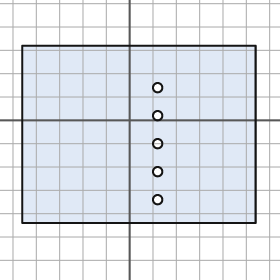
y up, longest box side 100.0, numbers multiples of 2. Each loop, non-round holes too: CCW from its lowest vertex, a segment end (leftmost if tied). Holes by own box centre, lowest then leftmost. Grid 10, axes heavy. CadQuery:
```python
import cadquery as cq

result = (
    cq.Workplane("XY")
    .moveTo(-46.0, -44.0)
    .lineTo(54.0, -44.0)
    .lineTo(54.0, 32.0)
    .lineTo(-46.0, 32.0)
    .close()
    .moveTo(12.0, -34.0)
    .circle(2.0)
    .moveTo(12.0, -22.0)
    .circle(2.0)
    .moveTo(12.0, -10.0)
    .circle(2.0)
    .moveTo(12.0, 2.0)
    .circle(2.0)
    .moveTo(12.0, 14.0)
    .circle(2.0)
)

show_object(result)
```